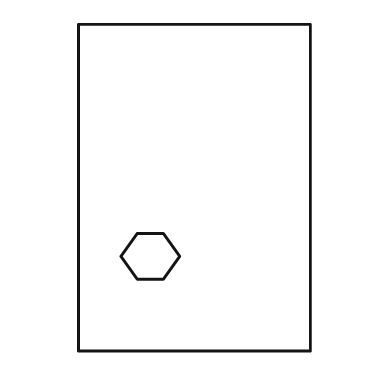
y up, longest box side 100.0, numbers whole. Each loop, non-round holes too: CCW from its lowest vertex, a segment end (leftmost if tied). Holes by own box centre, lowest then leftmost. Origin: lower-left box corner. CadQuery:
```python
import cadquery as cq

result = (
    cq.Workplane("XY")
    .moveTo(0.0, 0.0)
    .lineTo(71.0, 0.0)
    .lineTo(71.0, 100.0)
    .lineTo(0.0, 100.0)
    .close()
    .moveTo(18.0, 22.0)
    .lineTo(26.0, 22.0)
    .lineTo(31.0, 29.0)
    .lineTo(26.0, 36.0)
    .lineTo(18.0, 36.0)
    .lineTo(13.0, 29.0)
    .close()
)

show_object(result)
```